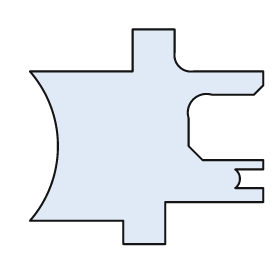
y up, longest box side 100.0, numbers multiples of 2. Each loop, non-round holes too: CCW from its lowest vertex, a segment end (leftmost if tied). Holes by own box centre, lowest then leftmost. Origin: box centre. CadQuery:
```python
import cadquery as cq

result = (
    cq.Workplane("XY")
    .moveTo(-10.0, -46.0)
    .lineTo(8.0, -46.0)
    .lineTo(8.0, -28.0)
    .lineTo(50.0, -28.0)
    .lineTo(50.0, -22.0)
    .lineTo(38.0, -22.0)
    .threePointArc((40.0, -18.0), (38.0, -14.0))
    .lineTo(50.0, -14.0)
    .lineTo(50.0, -10.0)
    .lineTo(24.0, -10.0)
    .lineTo(18.0, -4.0)
    .lineTo(18.0, 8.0)
    .threePointArc((20.0, 16.0), (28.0, 18.0))
    .lineTo(46.0, 18.0)
    .lineTo(50.0, 22.0)
    .lineTo(50.0, 28.0)
    .lineTo(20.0, 28.0)
    .threePointArc((14.0, 30.0), (12.0, 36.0))
    .lineTo(12.0, 46.0)
    .lineTo(-6.0, 46.0)
    .lineTo(-6.0, 28.0)
    .lineTo(-50.0, 28.0)
    .threePointArc((-38.0, -4.0), (-50.0, -36.0))
    .lineTo(-10.0, -36.0)
    .close()
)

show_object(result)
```